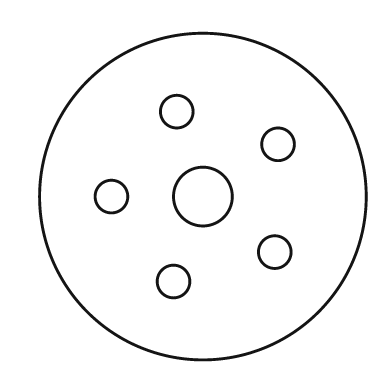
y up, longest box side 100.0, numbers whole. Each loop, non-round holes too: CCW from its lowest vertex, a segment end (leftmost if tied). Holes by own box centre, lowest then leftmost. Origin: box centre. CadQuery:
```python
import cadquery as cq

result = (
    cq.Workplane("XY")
    .moveTo(0.0, 0.0)
    .circle(50.0)
    .moveTo(-9.0, -26.0)
    .circle(5.0)
    .moveTo(22.0, -17.0)
    .circle(5.0)
    .moveTo(-28.0, 0.0)
    .circle(5.0)
    .moveTo(0.0, 0.0)
    .circle(9.0)
    .moveTo(23.0, 16.0)
    .circle(5.0)
    .moveTo(-8.0, 26.0)
    .circle(5.0)
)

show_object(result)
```